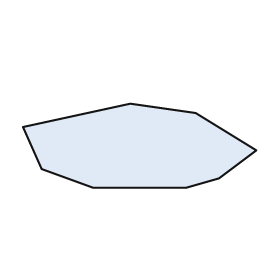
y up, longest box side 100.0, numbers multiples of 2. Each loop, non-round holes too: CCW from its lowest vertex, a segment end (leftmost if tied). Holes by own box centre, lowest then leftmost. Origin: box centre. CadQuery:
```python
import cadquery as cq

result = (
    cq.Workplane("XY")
    .moveTo(-20.0, -18.0)
    .lineTo(20.0, -18.0)
    .lineTo(34.0, -14.0)
    .lineTo(50.0, -2.0)
    .lineTo(24.0, 14.0)
    .lineTo(-4.0, 18.0)
    .lineTo(-50.0, 8.0)
    .lineTo(-42.0, -10.0)
    .close()
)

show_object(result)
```